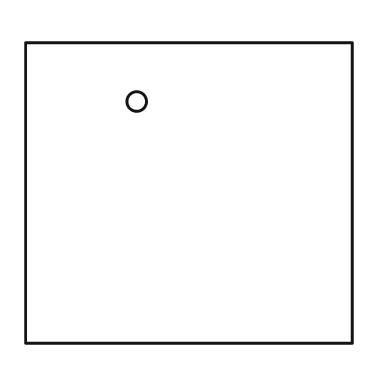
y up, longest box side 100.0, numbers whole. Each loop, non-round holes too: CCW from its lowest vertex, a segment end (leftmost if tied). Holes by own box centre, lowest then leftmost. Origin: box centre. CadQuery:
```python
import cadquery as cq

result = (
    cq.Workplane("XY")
    .moveTo(-50.0, -46.0)
    .lineTo(50.0, -46.0)
    .lineTo(50.0, 46.0)
    .lineTo(-50.0, 46.0)
    .close()
    .moveTo(-16.0, 28.0)
    .circle(3.0)
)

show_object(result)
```